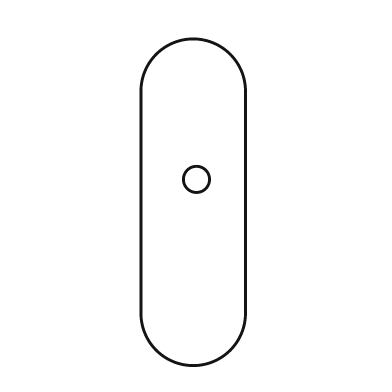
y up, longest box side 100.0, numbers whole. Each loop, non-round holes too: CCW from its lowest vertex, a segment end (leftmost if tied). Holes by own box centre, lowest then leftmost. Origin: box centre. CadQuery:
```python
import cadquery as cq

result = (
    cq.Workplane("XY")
    .moveTo(-16.0, -34.0)
    .threePointArc((0.0, -50.0), (16.0, -34.0))
    .lineTo(16.0, 34.0)
    .threePointArc((0.0, 50.0), (-16.0, 34.0))
    .close()
    .moveTo(1.0, 7.0)
    .circle(4.0)
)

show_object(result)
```